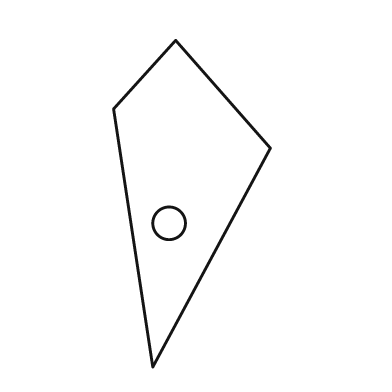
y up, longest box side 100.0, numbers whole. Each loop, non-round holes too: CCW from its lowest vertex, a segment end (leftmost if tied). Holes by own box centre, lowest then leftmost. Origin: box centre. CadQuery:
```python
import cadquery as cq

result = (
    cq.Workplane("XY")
    .moveTo(-12.0, -50.0)
    .lineTo(24.0, 17.0)
    .lineTo(-5.0, 50.0)
    .lineTo(-24.0, 29.0)
    .close()
    .moveTo(-7.0, -6.0)
    .circle(5.0)
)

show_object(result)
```